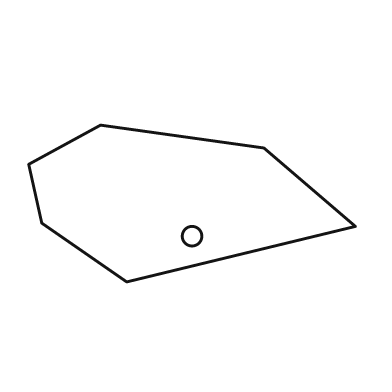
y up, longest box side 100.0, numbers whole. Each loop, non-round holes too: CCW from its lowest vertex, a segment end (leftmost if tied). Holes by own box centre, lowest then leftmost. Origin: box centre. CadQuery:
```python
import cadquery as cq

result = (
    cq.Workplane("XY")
    .moveTo(-20.0, -24.0)
    .lineTo(50.0, -7.0)
    .lineTo(22.0, 17.0)
    .lineTo(-28.0, 24.0)
    .lineTo(-50.0, 12.0)
    .lineTo(-46.0, -6.0)
    .close()
    .moveTo(0.0, -10.0)
    .circle(3.0)
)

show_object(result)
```